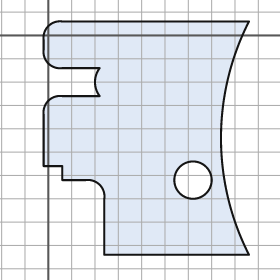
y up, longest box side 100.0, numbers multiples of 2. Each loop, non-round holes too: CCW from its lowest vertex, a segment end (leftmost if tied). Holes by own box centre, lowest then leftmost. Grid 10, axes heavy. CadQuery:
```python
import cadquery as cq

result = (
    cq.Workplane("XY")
    .moveTo(24.0, -94.0)
    .lineTo(86.0, -94.0)
    .threePointArc((74.0, -44.0), (86.0, 6.0))
    .lineTo(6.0, 6.0)
    .threePointArc((0.0, 4.0), (-2.0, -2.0))
    .lineTo(-2.0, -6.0)
    .threePointArc((0.0, -12.0), (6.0, -14.0))
    .lineTo(22.0, -14.0)
    .threePointArc((20.0, -20.0), (22.0, -26.0))
    .lineTo(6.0, -26.0)
    .threePointArc((0.0, -28.0), (-2.0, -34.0))
    .lineTo(-2.0, -56.0)
    .lineTo(6.0, -56.0)
    .lineTo(6.0, -62.0)
    .lineTo(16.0, -62.0)
    .threePointArc((22.0, -64.0), (24.0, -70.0))
    .close()
    .moveTo(62.0, -62.0)
    .circle(8.0)
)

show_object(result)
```